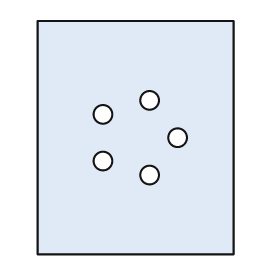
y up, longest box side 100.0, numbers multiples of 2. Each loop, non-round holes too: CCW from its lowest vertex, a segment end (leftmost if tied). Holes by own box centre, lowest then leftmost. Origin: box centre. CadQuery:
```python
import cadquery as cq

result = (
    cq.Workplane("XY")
    .moveTo(-42.0, -50.0)
    .lineTo(42.0, -50.0)
    .lineTo(42.0, 50.0)
    .lineTo(-42.0, 50.0)
    .close()
    .moveTo(6.0, -16.0)
    .circle(4.0)
    .moveTo(-14.0, -10.0)
    .circle(4.0)
    .moveTo(18.0, 0.0)
    .circle(4.0)
    .moveTo(-14.0, 10.0)
    .circle(4.0)
    .moveTo(6.0, 16.0)
    .circle(4.0)
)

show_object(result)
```